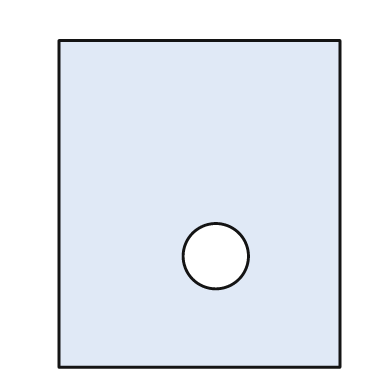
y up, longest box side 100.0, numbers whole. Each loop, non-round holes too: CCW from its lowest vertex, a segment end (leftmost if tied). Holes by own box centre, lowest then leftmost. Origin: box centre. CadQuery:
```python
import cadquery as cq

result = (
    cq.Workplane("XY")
    .moveTo(-43.0, -50.0)
    .lineTo(43.0, -50.0)
    .lineTo(43.0, 50.0)
    .lineTo(-43.0, 50.0)
    .close()
    .moveTo(5.0, -16.0)
    .circle(10.0)
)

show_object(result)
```